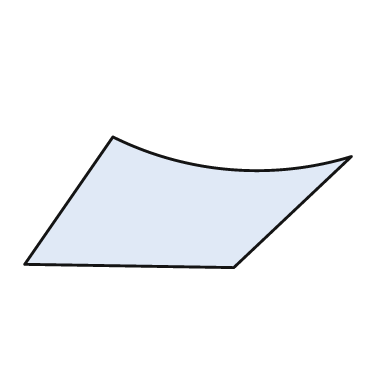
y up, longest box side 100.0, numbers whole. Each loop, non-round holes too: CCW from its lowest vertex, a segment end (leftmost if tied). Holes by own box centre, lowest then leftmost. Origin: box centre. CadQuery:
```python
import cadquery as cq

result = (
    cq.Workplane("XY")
    .moveTo(14.0, -20.0)
    .lineTo(50.0, 14.0)
    .threePointArc((13.0, 10.0), (-23.0, 20.0))
    .lineTo(-50.0, -19.0)
    .close()
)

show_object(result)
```